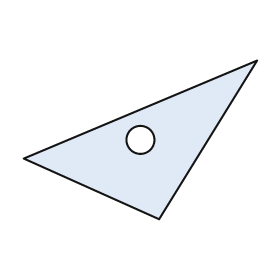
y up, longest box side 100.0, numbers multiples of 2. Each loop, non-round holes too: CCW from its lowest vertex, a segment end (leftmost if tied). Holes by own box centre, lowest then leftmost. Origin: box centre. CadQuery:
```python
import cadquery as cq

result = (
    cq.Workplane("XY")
    .moveTo(8.0, -34.0)
    .lineTo(50.0, 34.0)
    .lineTo(-50.0, -8.0)
    .close()
    .moveTo(0.0, 0.0)
    .circle(6.0)
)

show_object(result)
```